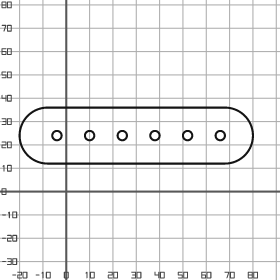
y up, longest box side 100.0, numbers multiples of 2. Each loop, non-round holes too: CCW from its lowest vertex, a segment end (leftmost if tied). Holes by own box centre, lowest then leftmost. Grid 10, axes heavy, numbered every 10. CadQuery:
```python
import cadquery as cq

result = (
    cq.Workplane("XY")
    .moveTo(-8.0, 12.0)
    .lineTo(68.0, 12.0)
    .threePointArc((80.0, 24.0), (68.0, 36.0))
    .lineTo(-8.0, 36.0)
    .threePointArc((-20.0, 24.0), (-8.0, 12.0))
    .close()
    .moveTo(-4.0, 24.0)
    .circle(2.0)
    .moveTo(10.0, 24.0)
    .circle(2.0)
    .moveTo(24.0, 24.0)
    .circle(2.0)
    .moveTo(38.0, 24.0)
    .circle(2.0)
    .moveTo(52.0, 24.0)
    .circle(2.0)
    .moveTo(66.0, 24.0)
    .circle(2.0)
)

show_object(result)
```